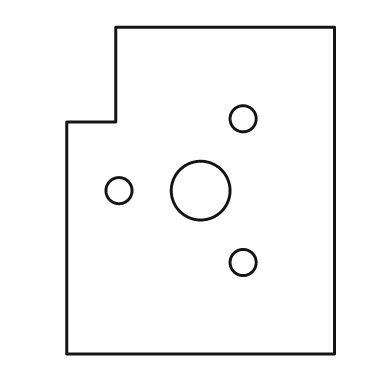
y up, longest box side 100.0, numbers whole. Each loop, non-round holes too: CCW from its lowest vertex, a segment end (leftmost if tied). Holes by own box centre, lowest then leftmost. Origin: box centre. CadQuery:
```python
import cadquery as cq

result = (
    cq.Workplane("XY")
    .moveTo(-41.0, -50.0)
    .lineTo(41.0, -50.0)
    .lineTo(41.0, 50.0)
    .lineTo(-26.0, 50.0)
    .lineTo(-26.0, 21.0)
    .lineTo(-41.0, 21.0)
    .close()
    .moveTo(13.0, -22.0)
    .circle(4.0)
    .moveTo(-25.0, 0.0)
    .circle(4.0)
    .moveTo(0.0, 0.0)
    .circle(9.0)
    .moveTo(13.0, 22.0)
    .circle(4.0)
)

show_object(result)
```